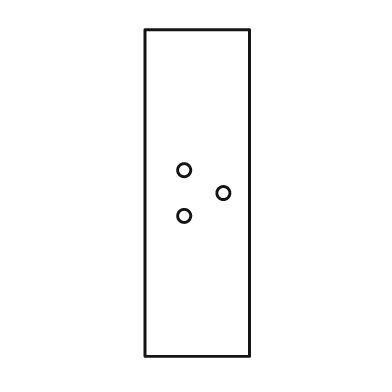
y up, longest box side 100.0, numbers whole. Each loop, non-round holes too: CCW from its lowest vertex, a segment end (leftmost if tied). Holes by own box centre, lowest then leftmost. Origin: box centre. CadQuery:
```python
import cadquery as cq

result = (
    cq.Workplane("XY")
    .moveTo(-16.0, -50.0)
    .lineTo(16.0, -50.0)
    .lineTo(16.0, 50.0)
    .lineTo(-16.0, 50.0)
    .close()
    .moveTo(-4.0, -7.0)
    .circle(2.0)
    .moveTo(8.0, 0.0)
    .circle(2.0)
    .moveTo(-4.0, 7.0)
    .circle(2.0)
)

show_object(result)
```